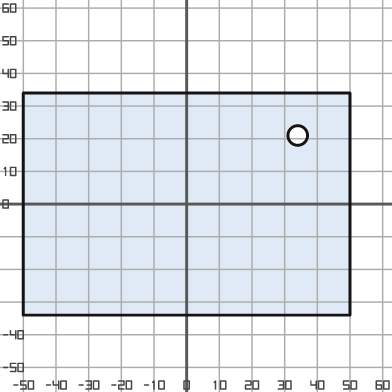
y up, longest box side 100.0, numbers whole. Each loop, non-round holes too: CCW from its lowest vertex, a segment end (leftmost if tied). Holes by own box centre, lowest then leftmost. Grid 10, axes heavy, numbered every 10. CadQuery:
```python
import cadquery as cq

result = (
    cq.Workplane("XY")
    .moveTo(-50.0, -34.0)
    .lineTo(50.0, -34.0)
    .lineTo(50.0, 34.0)
    .lineTo(-50.0, 34.0)
    .close()
    .moveTo(34.0, 21.0)
    .circle(3.0)
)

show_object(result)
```